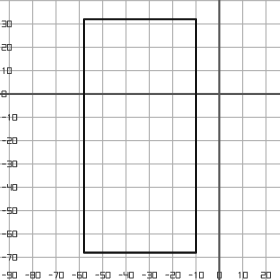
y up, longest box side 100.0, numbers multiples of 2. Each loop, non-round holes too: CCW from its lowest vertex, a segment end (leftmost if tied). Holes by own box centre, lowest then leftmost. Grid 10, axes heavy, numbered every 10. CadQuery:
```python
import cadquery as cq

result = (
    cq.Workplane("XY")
    .moveTo(-58.0, -68.0)
    .lineTo(-10.0, -68.0)
    .lineTo(-10.0, 32.0)
    .lineTo(-58.0, 32.0)
    .close()
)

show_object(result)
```